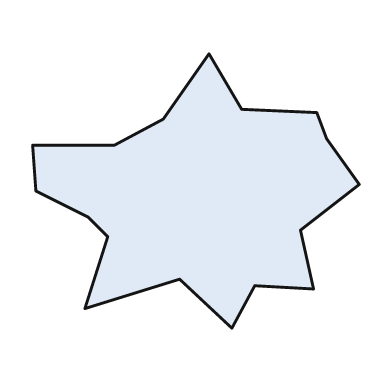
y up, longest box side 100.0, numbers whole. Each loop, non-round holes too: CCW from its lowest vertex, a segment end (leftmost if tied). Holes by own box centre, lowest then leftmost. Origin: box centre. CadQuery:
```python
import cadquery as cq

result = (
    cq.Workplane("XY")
    .moveTo(11.0, -42.0)
    .lineTo(18.0, -29.0)
    .lineTo(36.0, -30.0)
    .lineTo(32.0, -12.0)
    .lineTo(50.0, 2.0)
    .lineTo(40.0, 16.0)
    .lineTo(37.0, 24.0)
    .lineTo(14.0, 25.0)
    .lineTo(4.0, 42.0)
    .lineTo(-10.0, 22.0)
    .lineTo(-25.0, 14.0)
    .lineTo(-50.0, 14.0)
    .lineTo(-49.0, 0.0)
    .lineTo(-33.0, -8.0)
    .lineTo(-27.0, -14.0)
    .lineTo(-34.0, -36.0)
    .lineTo(-5.0, -27.0)
    .close()
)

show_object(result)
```